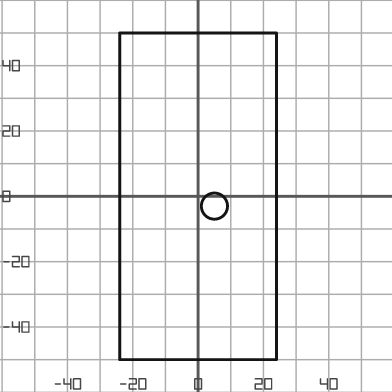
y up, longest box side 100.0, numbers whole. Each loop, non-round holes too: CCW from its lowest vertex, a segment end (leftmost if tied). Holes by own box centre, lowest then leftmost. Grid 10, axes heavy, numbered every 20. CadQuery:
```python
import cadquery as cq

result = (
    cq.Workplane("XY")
    .moveTo(-24.0, -50.0)
    .lineTo(24.0, -50.0)
    .lineTo(24.0, 50.0)
    .lineTo(-24.0, 50.0)
    .close()
    .moveTo(5.0, -3.0)
    .circle(4.0)
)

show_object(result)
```